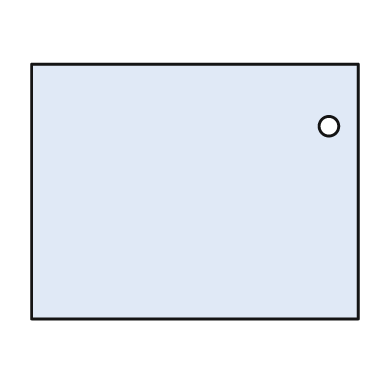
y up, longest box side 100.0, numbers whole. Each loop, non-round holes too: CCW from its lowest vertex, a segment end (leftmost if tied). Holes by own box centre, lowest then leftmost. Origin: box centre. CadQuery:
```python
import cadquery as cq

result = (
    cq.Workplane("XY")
    .moveTo(-50.0, -39.0)
    .lineTo(50.0, -39.0)
    .lineTo(50.0, 39.0)
    .lineTo(-50.0, 39.0)
    .close()
    .moveTo(41.0, 20.0)
    .circle(3.0)
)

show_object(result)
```